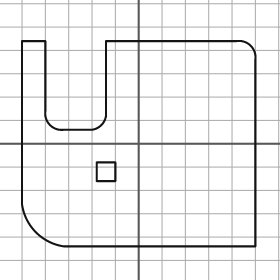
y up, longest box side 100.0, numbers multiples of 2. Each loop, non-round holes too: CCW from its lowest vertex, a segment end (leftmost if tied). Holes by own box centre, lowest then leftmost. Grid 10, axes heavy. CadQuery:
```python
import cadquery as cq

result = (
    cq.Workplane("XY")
    .moveTo(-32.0, -44.0)
    .lineTo(50.0, -44.0)
    .lineTo(50.0, 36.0)
    .threePointArc((48.0, 42.0), (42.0, 44.0))
    .lineTo(-14.0, 44.0)
    .lineTo(-14.0, 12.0)
    .threePointArc((-16.0, 8.0), (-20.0, 6.0))
    .lineTo(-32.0, 6.0)
    .threePointArc((-38.0, 8.0), (-40.0, 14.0))
    .lineTo(-40.0, 44.0)
    .lineTo(-50.0, 44.0)
    .lineTo(-50.0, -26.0)
    .threePointArc((-44.0, -38.0), (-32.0, -44.0))
    .close()
    .moveTo(-18.0, -16.0)
    .lineTo(-10.0, -16.0)
    .lineTo(-10.0, -8.0)
    .lineTo(-18.0, -8.0)
    .close()
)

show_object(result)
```